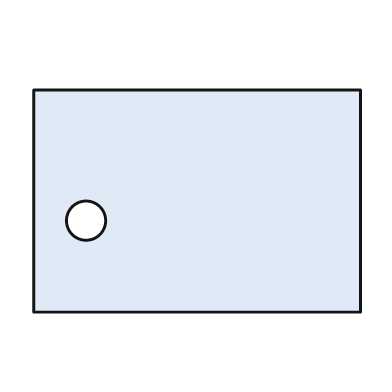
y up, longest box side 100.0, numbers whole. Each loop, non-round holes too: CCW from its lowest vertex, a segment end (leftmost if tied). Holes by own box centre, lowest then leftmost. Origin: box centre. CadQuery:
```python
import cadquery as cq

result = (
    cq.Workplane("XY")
    .moveTo(-50.0, -34.0)
    .lineTo(50.0, -34.0)
    .lineTo(50.0, 34.0)
    .lineTo(-50.0, 34.0)
    .close()
    .moveTo(-34.0, -6.0)
    .circle(6.0)
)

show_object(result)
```